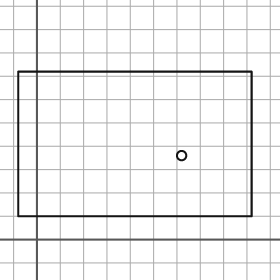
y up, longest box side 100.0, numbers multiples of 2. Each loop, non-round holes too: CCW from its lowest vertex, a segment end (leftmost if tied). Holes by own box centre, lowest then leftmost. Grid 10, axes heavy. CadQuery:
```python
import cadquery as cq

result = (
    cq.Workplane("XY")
    .moveTo(-8.0, 10.0)
    .lineTo(92.0, 10.0)
    .lineTo(92.0, 72.0)
    .lineTo(-8.0, 72.0)
    .close()
    .moveTo(62.0, 36.0)
    .circle(2.0)
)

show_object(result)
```